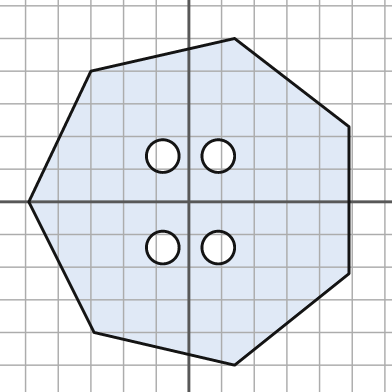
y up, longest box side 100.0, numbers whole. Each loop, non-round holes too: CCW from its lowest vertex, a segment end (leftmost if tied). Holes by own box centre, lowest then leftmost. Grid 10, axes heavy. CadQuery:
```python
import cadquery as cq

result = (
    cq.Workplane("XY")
    .moveTo(14.0, -50.0)
    .lineTo(49.0, -22.0)
    .lineTo(49.0, 23.0)
    .lineTo(14.0, 50.0)
    .lineTo(-30.0, 40.0)
    .lineTo(-49.0, 0.0)
    .lineTo(-29.0, -40.0)
    .close()
    .moveTo(-8.0, -14.0)
    .circle(5.0)
    .moveTo(9.0, -14.0)
    .circle(5.0)
    .moveTo(-8.0, 14.0)
    .circle(5.0)
    .moveTo(9.0, 14.0)
    .circle(5.0)
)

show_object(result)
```